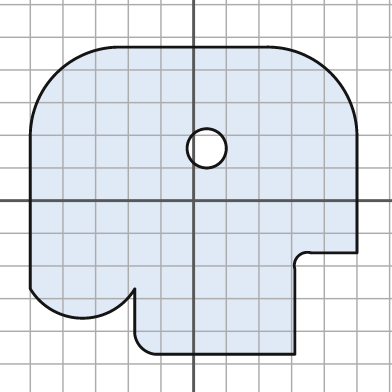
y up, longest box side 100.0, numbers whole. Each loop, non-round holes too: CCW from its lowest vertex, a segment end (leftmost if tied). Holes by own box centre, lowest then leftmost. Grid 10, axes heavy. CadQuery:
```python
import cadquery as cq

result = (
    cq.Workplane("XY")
    .moveTo(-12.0, -47.0)
    .lineTo(31.0, -47.0)
    .lineTo(31.0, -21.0)
    .threePointArc((32.0, -17.0), (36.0, -16.0))
    .lineTo(50.0, -16.0)
    .lineTo(50.0, 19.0)
    .threePointArc((42.0, 39.0), (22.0, 47.0))
    .lineTo(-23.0, 47.0)
    .threePointArc((-42.0, 39.0), (-50.0, 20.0))
    .lineTo(-50.0, -27.0)
    .threePointArc((-34.0, -36.0), (-18.0, -27.0))
    .lineTo(-18.0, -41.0)
    .threePointArc((-16.0, -45.0), (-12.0, -47.0))
    .close()
    .moveTo(4.0, 16.0)
    .circle(6.0)
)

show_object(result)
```